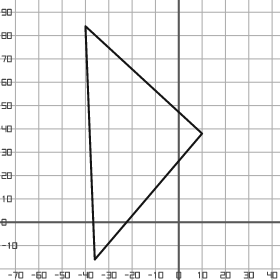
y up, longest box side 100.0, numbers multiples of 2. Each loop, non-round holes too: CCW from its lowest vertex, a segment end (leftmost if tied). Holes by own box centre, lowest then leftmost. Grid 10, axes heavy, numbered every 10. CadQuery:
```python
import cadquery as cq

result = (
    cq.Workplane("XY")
    .moveTo(-36.0, -16.0)
    .lineTo(10.0, 38.0)
    .lineTo(-40.0, 84.0)
    .close()
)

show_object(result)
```